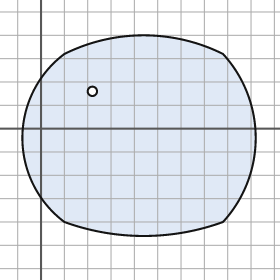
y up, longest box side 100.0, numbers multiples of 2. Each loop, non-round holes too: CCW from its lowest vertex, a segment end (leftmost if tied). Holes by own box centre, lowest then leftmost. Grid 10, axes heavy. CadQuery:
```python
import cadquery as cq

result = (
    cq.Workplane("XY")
    .moveTo(10.0, -40.0)
    .threePointArc((44.0, -46.0), (78.0, -40.0))
    .threePointArc((92.0, -4.0), (78.0, 32.0))
    .threePointArc((44.0, 40.0), (10.0, 32.0))
    .threePointArc((-8.0, -4.0), (10.0, -40.0))
    .close()
    .moveTo(22.0, 16.0)
    .circle(2.0)
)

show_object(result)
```